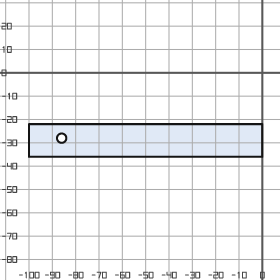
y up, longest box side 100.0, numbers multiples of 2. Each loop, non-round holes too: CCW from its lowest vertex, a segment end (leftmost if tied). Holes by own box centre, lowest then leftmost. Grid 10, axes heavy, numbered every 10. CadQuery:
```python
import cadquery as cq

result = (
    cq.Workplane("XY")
    .moveTo(-100.0, -36.0)
    .lineTo(0.0, -36.0)
    .lineTo(0.0, -22.0)
    .lineTo(-100.0, -22.0)
    .close()
    .moveTo(-86.0, -28.0)
    .circle(2.0)
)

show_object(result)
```